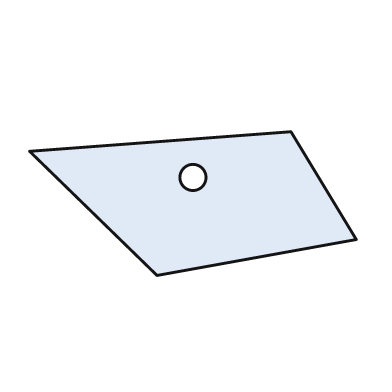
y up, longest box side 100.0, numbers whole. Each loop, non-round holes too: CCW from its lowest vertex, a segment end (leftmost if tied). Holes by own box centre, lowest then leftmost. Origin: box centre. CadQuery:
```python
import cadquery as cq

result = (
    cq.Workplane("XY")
    .moveTo(-11.0, -22.0)
    .lineTo(50.0, -11.0)
    .lineTo(30.0, 22.0)
    .lineTo(-50.0, 16.0)
    .close()
    .moveTo(0.0, 8.0)
    .circle(4.0)
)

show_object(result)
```